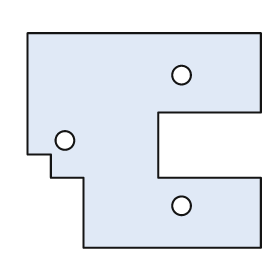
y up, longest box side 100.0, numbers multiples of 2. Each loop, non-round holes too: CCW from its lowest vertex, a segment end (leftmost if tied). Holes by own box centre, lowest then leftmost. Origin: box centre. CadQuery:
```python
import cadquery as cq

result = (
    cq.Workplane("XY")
    .moveTo(-26.0, -46.0)
    .lineTo(50.0, -46.0)
    .lineTo(50.0, -16.0)
    .lineTo(6.0, -16.0)
    .lineTo(6.0, 12.0)
    .lineTo(50.0, 12.0)
    .lineTo(50.0, 46.0)
    .lineTo(-50.0, 46.0)
    .lineTo(-50.0, -6.0)
    .lineTo(-40.0, -6.0)
    .lineTo(-40.0, -16.0)
    .lineTo(-26.0, -16.0)
    .close()
    .moveTo(16.0, -28.0)
    .circle(4.0)
    .moveTo(-34.0, 0.0)
    .circle(4.0)
    .moveTo(16.0, 28.0)
    .circle(4.0)
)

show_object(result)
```